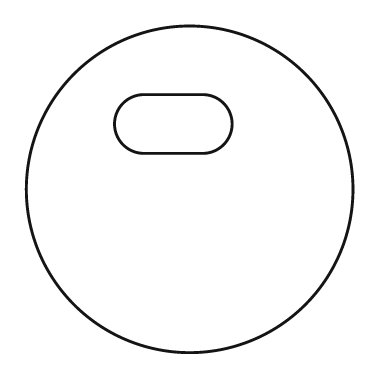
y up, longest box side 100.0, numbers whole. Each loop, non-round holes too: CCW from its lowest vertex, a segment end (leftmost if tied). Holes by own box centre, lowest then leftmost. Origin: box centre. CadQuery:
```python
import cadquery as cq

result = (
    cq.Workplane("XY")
    .moveTo(0.0, 0.0)
    .circle(50.0)
    .moveTo(-14.0, 11.0)
    .lineTo(4.0, 11.0)
    .threePointArc((13.0, 20.0), (4.0, 29.0))
    .lineTo(-14.0, 29.0)
    .threePointArc((-23.0, 20.0), (-14.0, 11.0))
    .close()
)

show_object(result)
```